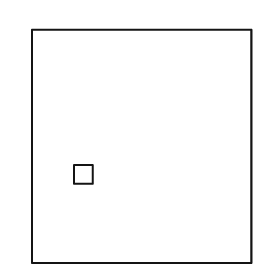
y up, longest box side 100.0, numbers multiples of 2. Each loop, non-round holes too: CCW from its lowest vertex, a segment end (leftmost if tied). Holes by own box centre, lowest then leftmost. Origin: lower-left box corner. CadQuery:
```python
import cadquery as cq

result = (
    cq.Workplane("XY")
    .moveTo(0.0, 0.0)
    .lineTo(94.0, 0.0)
    .lineTo(94.0, 100.0)
    .lineTo(0.0, 100.0)
    .close()
    .moveTo(18.0, 34.0)
    .lineTo(26.0, 34.0)
    .lineTo(26.0, 42.0)
    .lineTo(18.0, 42.0)
    .close()
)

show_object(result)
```